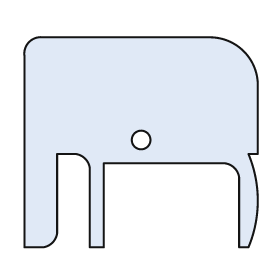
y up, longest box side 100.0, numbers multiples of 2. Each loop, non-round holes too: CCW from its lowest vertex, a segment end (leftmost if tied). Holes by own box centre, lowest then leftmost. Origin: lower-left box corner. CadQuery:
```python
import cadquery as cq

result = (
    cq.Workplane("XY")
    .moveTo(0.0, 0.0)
    .lineTo(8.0, 0.0)
    .threePointArc((12.0, 2.0), (14.0, 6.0))
    .lineTo(14.0, 40.0)
    .lineTo(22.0, 40.0)
    .threePointArc((26.0, 38.0), (28.0, 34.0))
    .lineTo(28.0, 0.0)
    .lineTo(34.0, 0.0)
    .lineTo(34.0, 36.0)
    .lineTo(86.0, 36.0)
    .threePointArc((90.0, 34.0), (92.0, 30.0))
    .lineTo(92.0, 0.0)
    .lineTo(96.0, 0.0)
    .threePointArc((100.0, 20.0), (96.0, 40.0))
    .lineTo(100.0, 40.0)
    .lineTo(100.0, 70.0)
    .threePointArc((94.0, 84.0), (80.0, 90.0))
    .lineTo(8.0, 90.0)
    .threePointArc((2.0, 88.0), (0.0, 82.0))
    .close()
    .moveTo(50.0, 46.0)
    .circle(4.0)
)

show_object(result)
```